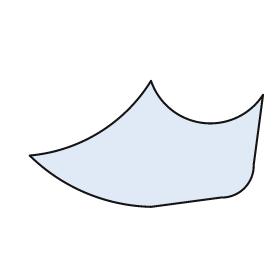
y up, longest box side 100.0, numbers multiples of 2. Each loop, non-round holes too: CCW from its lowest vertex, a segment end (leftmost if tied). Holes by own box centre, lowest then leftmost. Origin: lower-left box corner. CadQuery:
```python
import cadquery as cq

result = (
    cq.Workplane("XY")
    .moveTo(52.0, 0.0)
    .lineTo(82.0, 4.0)
    .threePointArc((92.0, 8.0), (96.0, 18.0))
    .lineTo(100.0, 48.0)
    .threePointArc((74.0, 36.0), (52.0, 54.0))
    .threePointArc((30.0, 32.0), (0.0, 22.0))
    .threePointArc((24.0, 6.0), (52.0, 0.0))
    .close()
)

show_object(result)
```